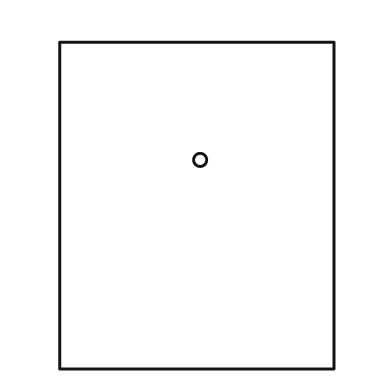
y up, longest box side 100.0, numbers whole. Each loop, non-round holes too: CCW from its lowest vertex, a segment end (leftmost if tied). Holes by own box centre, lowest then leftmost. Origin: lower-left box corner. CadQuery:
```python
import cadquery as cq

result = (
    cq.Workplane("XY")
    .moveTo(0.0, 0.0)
    .lineTo(84.0, 0.0)
    .lineTo(84.0, 100.0)
    .lineTo(0.0, 100.0)
    .close()
    .moveTo(43.0, 64.0)
    .circle(2.0)
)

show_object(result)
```